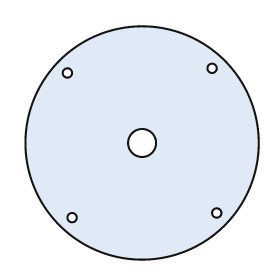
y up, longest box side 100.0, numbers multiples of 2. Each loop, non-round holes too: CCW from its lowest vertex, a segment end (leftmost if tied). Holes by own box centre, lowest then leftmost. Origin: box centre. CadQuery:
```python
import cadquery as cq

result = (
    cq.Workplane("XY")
    .moveTo(0.0, 0.0)
    .circle(50.0)
    .moveTo(-30.0, -32.0)
    .circle(2.0)
    .moveTo(32.0, -30.0)
    .circle(2.0)
    .moveTo(0.0, 0.0)
    .circle(6.0)
    .moveTo(-32.0, 30.0)
    .circle(2.0)
    .moveTo(30.0, 32.0)
    .circle(2.0)
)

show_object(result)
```